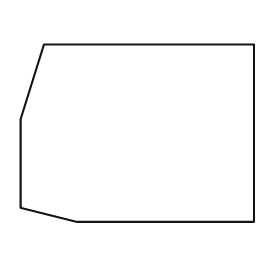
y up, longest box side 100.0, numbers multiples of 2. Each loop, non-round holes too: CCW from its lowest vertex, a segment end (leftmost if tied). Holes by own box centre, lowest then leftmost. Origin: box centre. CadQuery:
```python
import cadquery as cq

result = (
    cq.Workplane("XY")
    .moveTo(-26.0, -38.0)
    .lineTo(50.0, -38.0)
    .lineTo(50.0, 38.0)
    .lineTo(-40.0, 38.0)
    .lineTo(-50.0, 6.0)
    .lineTo(-50.0, -32.0)
    .close()
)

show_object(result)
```